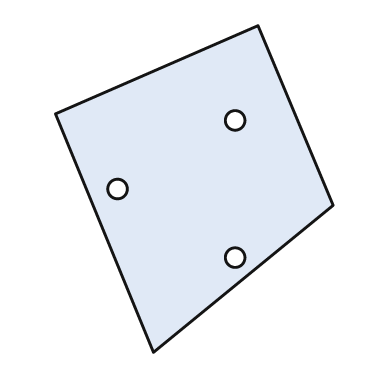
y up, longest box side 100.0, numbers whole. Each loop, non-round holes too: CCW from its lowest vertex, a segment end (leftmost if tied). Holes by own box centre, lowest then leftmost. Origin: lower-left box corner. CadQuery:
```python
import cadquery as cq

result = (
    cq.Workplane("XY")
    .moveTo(30.0, 0.0)
    .lineTo(85.0, 45.0)
    .lineTo(62.0, 100.0)
    .lineTo(0.0, 73.0)
    .close()
    .moveTo(55.0, 29.0)
    .circle(3.0)
    .moveTo(19.0, 50.0)
    .circle(3.0)
    .moveTo(55.0, 71.0)
    .circle(3.0)
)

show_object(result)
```